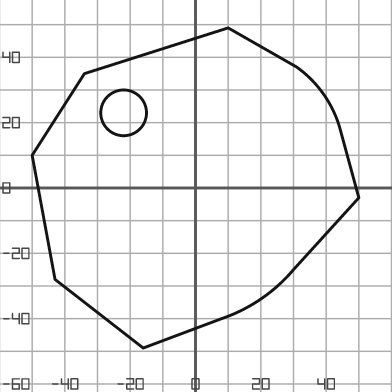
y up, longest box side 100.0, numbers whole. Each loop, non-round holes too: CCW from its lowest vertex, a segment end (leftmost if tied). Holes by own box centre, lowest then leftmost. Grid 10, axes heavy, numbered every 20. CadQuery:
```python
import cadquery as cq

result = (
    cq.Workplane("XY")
    .moveTo(-16.0, -49.0)
    .lineTo(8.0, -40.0)
    .threePointArc((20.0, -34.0), (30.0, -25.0))
    .lineTo(50.0, -3.0)
    .lineTo(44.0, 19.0)
    .threePointArc((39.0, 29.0), (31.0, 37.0))
    .lineTo(10.0, 49.0)
    .lineTo(-34.0, 35.0)
    .lineTo(-50.0, 10.0)
    .lineTo(-43.0, -28.0)
    .close()
    .moveTo(-22.0, 23.0)
    .circle(7.0)
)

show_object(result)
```